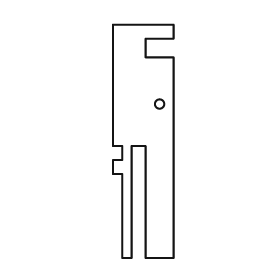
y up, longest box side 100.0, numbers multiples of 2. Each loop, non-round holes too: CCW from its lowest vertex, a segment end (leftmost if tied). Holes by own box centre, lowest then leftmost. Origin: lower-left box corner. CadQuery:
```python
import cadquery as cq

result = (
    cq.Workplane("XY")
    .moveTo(4.0, 0.0)
    .lineTo(8.0, 0.0)
    .lineTo(8.0, 48.0)
    .lineTo(14.0, 48.0)
    .lineTo(14.0, 0.0)
    .lineTo(26.0, 0.0)
    .lineTo(26.0, 86.0)
    .lineTo(14.0, 86.0)
    .lineTo(14.0, 94.0)
    .lineTo(26.0, 94.0)
    .lineTo(26.0, 100.0)
    .lineTo(0.0, 100.0)
    .lineTo(0.0, 48.0)
    .lineTo(4.0, 48.0)
    .lineTo(4.0, 42.0)
    .lineTo(0.0, 42.0)
    .lineTo(0.0, 36.0)
    .lineTo(4.0, 36.0)
    .close()
    .moveTo(20.0, 66.0)
    .circle(2.0)
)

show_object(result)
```